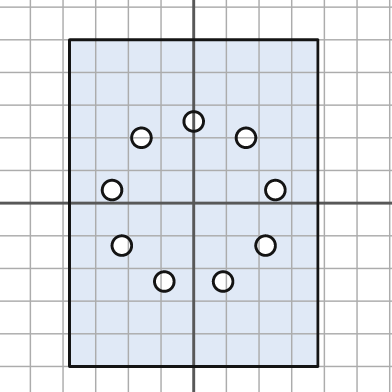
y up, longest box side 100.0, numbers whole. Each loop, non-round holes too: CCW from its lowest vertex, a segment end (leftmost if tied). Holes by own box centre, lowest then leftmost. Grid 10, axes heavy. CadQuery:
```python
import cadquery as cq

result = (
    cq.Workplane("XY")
    .moveTo(-38.0, -50.0)
    .lineTo(38.0, -50.0)
    .lineTo(38.0, 50.0)
    .lineTo(-38.0, 50.0)
    .close()
    .moveTo(-9.0, -24.0)
    .circle(3.0)
    .moveTo(9.0, -24.0)
    .circle(3.0)
    .moveTo(-22.0, -13.0)
    .circle(3.0)
    .moveTo(22.0, -13.0)
    .circle(3.0)
    .moveTo(-25.0, 4.0)
    .circle(3.0)
    .moveTo(25.0, 4.0)
    .circle(3.0)
    .moveTo(-16.0, 20.0)
    .circle(3.0)
    .moveTo(16.0, 20.0)
    .circle(3.0)
    .moveTo(0.0, 25.0)
    .circle(3.0)
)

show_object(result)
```